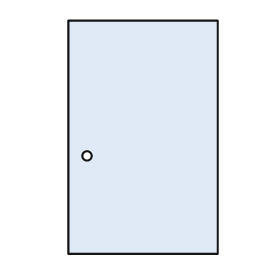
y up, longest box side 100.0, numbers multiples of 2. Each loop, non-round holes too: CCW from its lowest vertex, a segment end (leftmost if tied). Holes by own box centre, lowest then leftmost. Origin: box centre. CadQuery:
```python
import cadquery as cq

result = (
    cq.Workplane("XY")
    .moveTo(-32.0, -50.0)
    .lineTo(32.0, -50.0)
    .lineTo(32.0, 50.0)
    .lineTo(-32.0, 50.0)
    .close()
    .moveTo(-24.0, -8.0)
    .circle(2.0)
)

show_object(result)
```